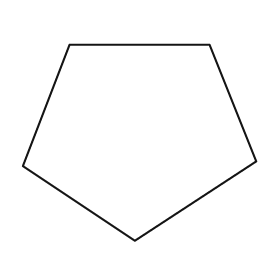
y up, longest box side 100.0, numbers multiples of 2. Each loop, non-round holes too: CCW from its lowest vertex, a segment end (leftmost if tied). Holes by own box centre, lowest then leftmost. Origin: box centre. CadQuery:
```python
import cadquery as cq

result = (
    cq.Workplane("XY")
    .moveTo(-2.0, -42.0)
    .lineTo(50.0, -8.0)
    .lineTo(30.0, 42.0)
    .lineTo(-30.0, 42.0)
    .lineTo(-50.0, -10.0)
    .close()
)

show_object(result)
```